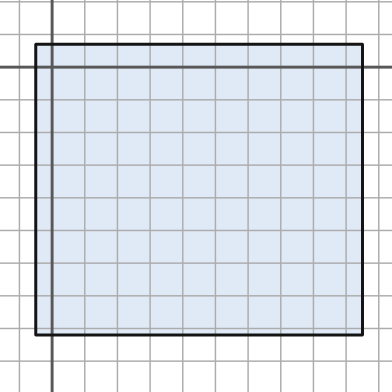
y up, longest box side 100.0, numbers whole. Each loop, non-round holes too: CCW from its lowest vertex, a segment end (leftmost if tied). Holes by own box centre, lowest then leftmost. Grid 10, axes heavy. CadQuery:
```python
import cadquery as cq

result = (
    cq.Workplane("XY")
    .moveTo(-5.0, -82.0)
    .lineTo(95.0, -82.0)
    .lineTo(95.0, 7.0)
    .lineTo(-5.0, 7.0)
    .close()
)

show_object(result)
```